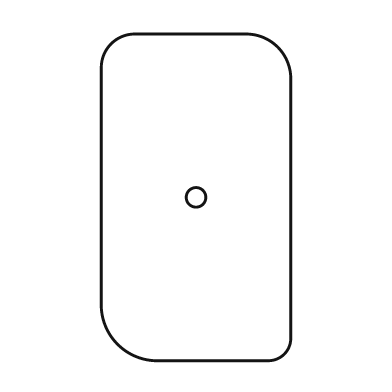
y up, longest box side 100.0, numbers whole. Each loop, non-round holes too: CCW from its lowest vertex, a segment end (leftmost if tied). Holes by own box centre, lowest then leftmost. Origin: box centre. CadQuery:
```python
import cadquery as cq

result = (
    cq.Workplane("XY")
    .moveTo(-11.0, -50.0)
    .lineTo(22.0, -50.0)
    .threePointArc((27.0, -48.0), (29.0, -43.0))
    .lineTo(29.0, 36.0)
    .threePointArc((25.0, 46.0), (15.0, 50.0))
    .lineTo(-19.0, 50.0)
    .threePointArc((-26.0, 47.0), (-29.0, 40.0))
    .lineTo(-29.0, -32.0)
    .threePointArc((-24.0, -45.0), (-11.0, -50.0))
    .close()
    .moveTo(0.0, 0.0)
    .circle(3.0)
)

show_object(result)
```